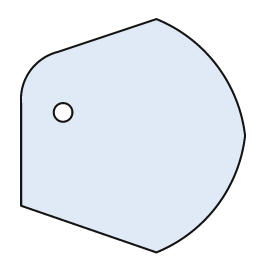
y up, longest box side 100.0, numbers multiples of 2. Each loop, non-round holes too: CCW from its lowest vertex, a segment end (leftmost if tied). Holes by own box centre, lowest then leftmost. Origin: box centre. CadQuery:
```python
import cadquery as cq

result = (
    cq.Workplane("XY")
    .moveTo(10.0, -50.0)
    .threePointArc((36.0, -30.0), (48.0, 0.0))
    .threePointArc((36.0, 30.0), (10.0, 50.0))
    .lineTo(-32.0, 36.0)
    .threePointArc((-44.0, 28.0), (-48.0, 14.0))
    .lineTo(-48.0, -30.0)
    .close()
    .moveTo(-30.0, 10.0)
    .circle(4.0)
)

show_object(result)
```